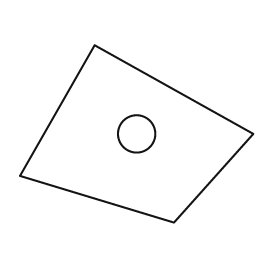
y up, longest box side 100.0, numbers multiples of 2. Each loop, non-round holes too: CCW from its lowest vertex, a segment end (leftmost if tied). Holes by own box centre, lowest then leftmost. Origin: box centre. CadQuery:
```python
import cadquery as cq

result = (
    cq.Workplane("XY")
    .moveTo(16.0, -38.0)
    .lineTo(50.0, 0.0)
    .lineTo(-18.0, 38.0)
    .lineTo(-50.0, -18.0)
    .close()
    .moveTo(0.0, 0.0)
    .circle(8.0)
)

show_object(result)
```